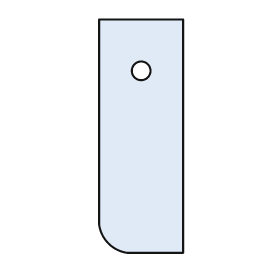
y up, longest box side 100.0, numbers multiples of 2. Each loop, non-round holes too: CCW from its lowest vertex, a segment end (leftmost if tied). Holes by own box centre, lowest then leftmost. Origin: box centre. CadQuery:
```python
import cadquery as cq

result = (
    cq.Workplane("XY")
    .moveTo(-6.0, -50.0)
    .lineTo(18.0, -50.0)
    .lineTo(18.0, 50.0)
    .lineTo(-18.0, 50.0)
    .lineTo(-18.0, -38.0)
    .threePointArc((-14.0, -46.0), (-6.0, -50.0))
    .close()
    .moveTo(0.0, 28.0)
    .circle(4.0)
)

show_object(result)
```